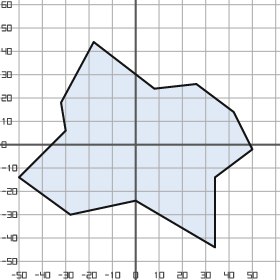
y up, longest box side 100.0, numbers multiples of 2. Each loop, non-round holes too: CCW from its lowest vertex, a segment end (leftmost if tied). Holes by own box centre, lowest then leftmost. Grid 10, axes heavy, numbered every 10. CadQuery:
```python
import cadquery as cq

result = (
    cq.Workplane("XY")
    .moveTo(34.0, -44.0)
    .lineTo(34.0, -14.0)
    .lineTo(50.0, -2.0)
    .lineTo(42.0, 14.0)
    .lineTo(26.0, 26.0)
    .lineTo(8.0, 24.0)
    .lineTo(-18.0, 44.0)
    .lineTo(-32.0, 18.0)
    .lineTo(-30.0, 6.0)
    .lineTo(-50.0, -14.0)
    .lineTo(-28.0, -30.0)
    .lineTo(0.0, -24.0)
    .close()
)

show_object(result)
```